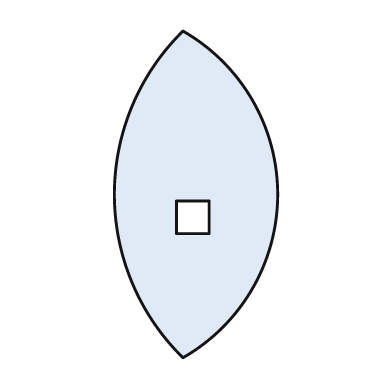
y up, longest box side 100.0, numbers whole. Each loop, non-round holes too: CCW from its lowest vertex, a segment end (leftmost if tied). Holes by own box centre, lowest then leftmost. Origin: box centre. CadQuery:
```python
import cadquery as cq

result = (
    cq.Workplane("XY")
    .moveTo(-4.0, -50.0)
    .threePointArc((25.0, 0.0), (-4.0, 50.0))
    .threePointArc((-25.0, 0.0), (-4.0, -50.0))
    .close()
    .moveTo(-6.0, -12.0)
    .lineTo(4.0, -12.0)
    .lineTo(4.0, -2.0)
    .lineTo(-6.0, -2.0)
    .close()
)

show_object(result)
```